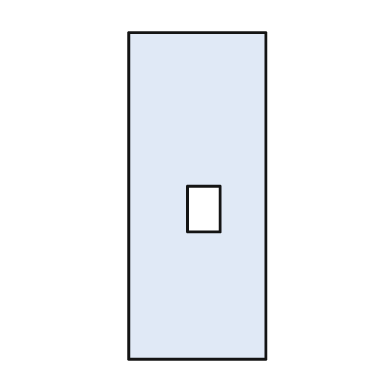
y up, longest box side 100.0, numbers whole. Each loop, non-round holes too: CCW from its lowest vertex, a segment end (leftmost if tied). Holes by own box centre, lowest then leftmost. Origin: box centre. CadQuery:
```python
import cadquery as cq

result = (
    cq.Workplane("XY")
    .moveTo(-21.0, -50.0)
    .lineTo(21.0, -50.0)
    .lineTo(21.0, 50.0)
    .lineTo(-21.0, 50.0)
    .close()
    .moveTo(-3.0, -11.0)
    .lineTo(7.0, -11.0)
    .lineTo(7.0, 3.0)
    .lineTo(-3.0, 3.0)
    .close()
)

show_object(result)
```